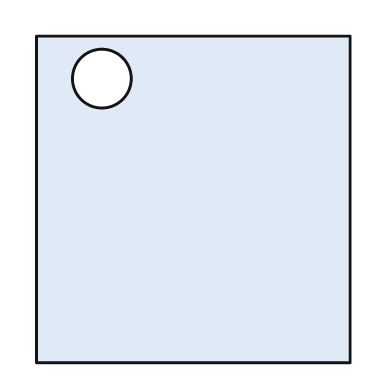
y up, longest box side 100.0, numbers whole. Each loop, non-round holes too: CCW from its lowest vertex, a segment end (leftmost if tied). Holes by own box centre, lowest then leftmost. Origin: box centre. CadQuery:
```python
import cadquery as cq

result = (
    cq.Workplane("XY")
    .moveTo(-48.0, -50.0)
    .lineTo(48.0, -50.0)
    .lineTo(48.0, 50.0)
    .lineTo(-48.0, 50.0)
    .close()
    .moveTo(-28.0, 37.0)
    .circle(9.0)
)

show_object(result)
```